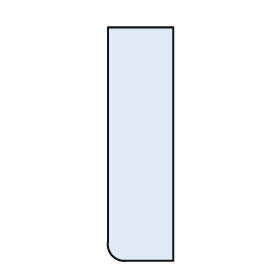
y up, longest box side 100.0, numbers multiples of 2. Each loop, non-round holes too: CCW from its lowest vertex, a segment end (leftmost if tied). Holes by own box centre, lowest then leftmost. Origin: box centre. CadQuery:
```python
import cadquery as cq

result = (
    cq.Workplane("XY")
    .moveTo(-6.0, -50.0)
    .lineTo(14.0, -50.0)
    .lineTo(14.0, 50.0)
    .lineTo(-14.0, 50.0)
    .lineTo(-14.0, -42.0)
    .threePointArc((-12.0, -48.0), (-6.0, -50.0))
    .close()
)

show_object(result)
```